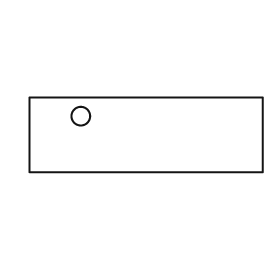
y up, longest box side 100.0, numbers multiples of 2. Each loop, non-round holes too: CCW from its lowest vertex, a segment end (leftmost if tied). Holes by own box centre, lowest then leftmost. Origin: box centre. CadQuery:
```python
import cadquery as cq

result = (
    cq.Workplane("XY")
    .moveTo(-50.0, -16.0)
    .lineTo(50.0, -16.0)
    .lineTo(50.0, 16.0)
    .lineTo(-50.0, 16.0)
    .close()
    .moveTo(-28.0, 8.0)
    .circle(4.0)
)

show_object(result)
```